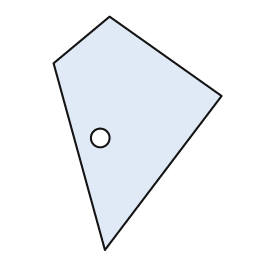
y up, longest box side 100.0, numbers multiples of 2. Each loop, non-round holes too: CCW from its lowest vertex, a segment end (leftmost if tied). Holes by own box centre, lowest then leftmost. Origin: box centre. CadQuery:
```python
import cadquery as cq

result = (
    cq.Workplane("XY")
    .moveTo(-14.0, -50.0)
    .lineTo(36.0, 16.0)
    .lineTo(-12.0, 50.0)
    .lineTo(-36.0, 30.0)
    .close()
    .moveTo(-16.0, -2.0)
    .circle(4.0)
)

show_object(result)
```